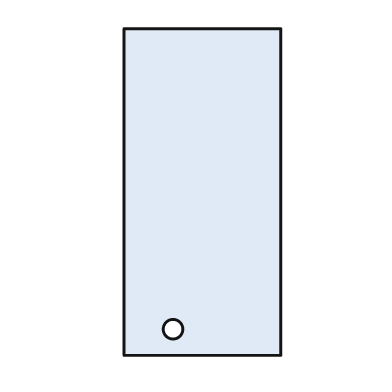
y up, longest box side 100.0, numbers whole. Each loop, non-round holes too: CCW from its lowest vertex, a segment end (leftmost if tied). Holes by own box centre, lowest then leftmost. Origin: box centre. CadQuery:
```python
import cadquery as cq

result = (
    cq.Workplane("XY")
    .moveTo(-24.0, -50.0)
    .lineTo(24.0, -50.0)
    .lineTo(24.0, 50.0)
    .lineTo(-24.0, 50.0)
    .close()
    .moveTo(-9.0, -42.0)
    .circle(3.0)
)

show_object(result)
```